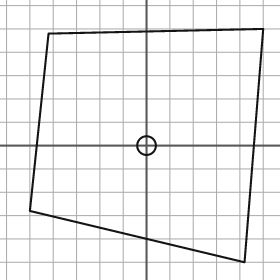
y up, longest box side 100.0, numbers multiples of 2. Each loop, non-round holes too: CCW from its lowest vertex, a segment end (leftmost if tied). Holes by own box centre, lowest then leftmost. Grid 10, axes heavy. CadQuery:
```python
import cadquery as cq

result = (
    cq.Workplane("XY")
    .moveTo(42.0, -50.0)
    .lineTo(50.0, 50.0)
    .lineTo(-42.0, 48.0)
    .lineTo(-50.0, -28.0)
    .close()
    .moveTo(0.0, 0.0)
    .circle(4.0)
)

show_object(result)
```